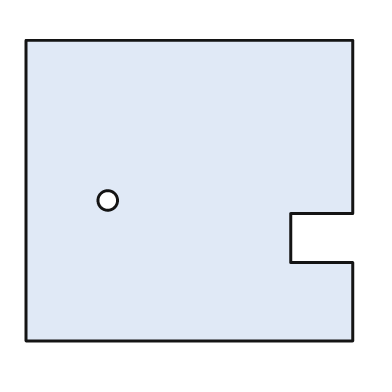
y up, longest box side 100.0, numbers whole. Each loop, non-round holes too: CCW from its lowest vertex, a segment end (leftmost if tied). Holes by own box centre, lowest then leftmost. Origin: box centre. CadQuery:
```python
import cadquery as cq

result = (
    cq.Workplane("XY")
    .moveTo(-50.0, -46.0)
    .lineTo(50.0, -46.0)
    .lineTo(50.0, -22.0)
    .lineTo(31.0, -22.0)
    .lineTo(31.0, -7.0)
    .lineTo(50.0, -7.0)
    .lineTo(50.0, 46.0)
    .lineTo(-50.0, 46.0)
    .close()
    .moveTo(-25.0, -3.0)
    .circle(3.0)
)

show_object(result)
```